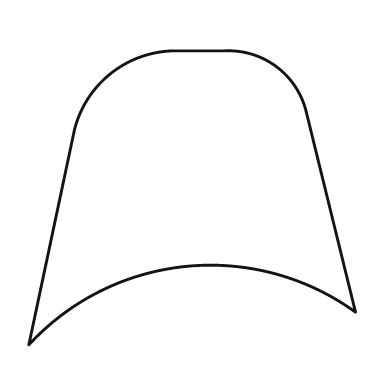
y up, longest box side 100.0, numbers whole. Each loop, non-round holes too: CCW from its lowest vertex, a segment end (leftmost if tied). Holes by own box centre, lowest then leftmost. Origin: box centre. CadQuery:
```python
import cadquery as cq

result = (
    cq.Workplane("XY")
    .moveTo(-50.0, -45.0)
    .threePointArc((-2.0, -21.0), (50.0, -35.0))
    .lineTo(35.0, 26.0)
    .threePointArc((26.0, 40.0), (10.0, 45.0))
    .lineTo(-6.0, 45.0)
    .threePointArc((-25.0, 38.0), (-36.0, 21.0))
    .close()
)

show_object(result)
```